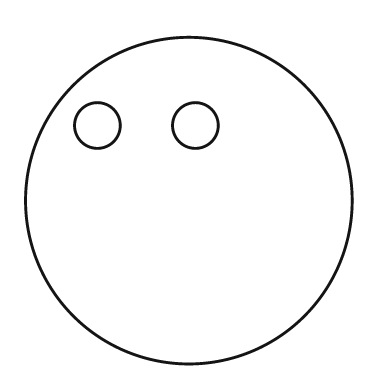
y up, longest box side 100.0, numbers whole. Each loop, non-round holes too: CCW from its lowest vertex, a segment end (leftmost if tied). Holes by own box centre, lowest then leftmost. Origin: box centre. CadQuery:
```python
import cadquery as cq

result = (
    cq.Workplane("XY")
    .moveTo(0.0, 0.0)
    .circle(50.0)
    .moveTo(-28.0, 23.0)
    .circle(7.0)
    .moveTo(2.0, 23.0)
    .circle(7.0)
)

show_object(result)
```